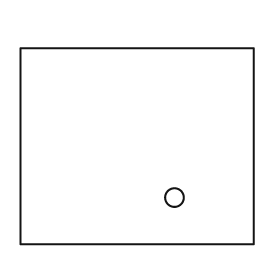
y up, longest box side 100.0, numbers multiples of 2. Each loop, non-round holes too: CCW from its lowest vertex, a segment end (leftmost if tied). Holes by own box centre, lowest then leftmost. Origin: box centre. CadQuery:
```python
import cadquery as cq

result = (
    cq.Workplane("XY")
    .moveTo(-50.0, -42.0)
    .lineTo(50.0, -42.0)
    .lineTo(50.0, 42.0)
    .lineTo(-50.0, 42.0)
    .close()
    .moveTo(16.0, -22.0)
    .circle(4.0)
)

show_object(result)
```